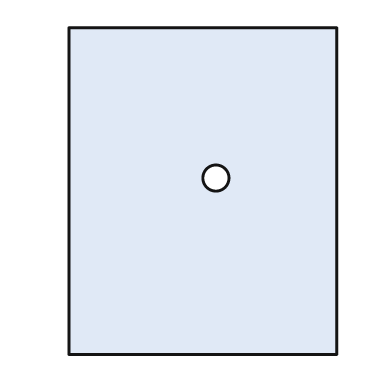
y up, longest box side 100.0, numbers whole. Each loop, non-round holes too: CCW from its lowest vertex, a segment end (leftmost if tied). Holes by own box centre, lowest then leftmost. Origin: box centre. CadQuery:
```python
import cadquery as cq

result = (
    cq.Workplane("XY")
    .moveTo(-41.0, -50.0)
    .lineTo(41.0, -50.0)
    .lineTo(41.0, 50.0)
    .lineTo(-41.0, 50.0)
    .close()
    .moveTo(4.0, 4.0)
    .circle(4.0)
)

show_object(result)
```